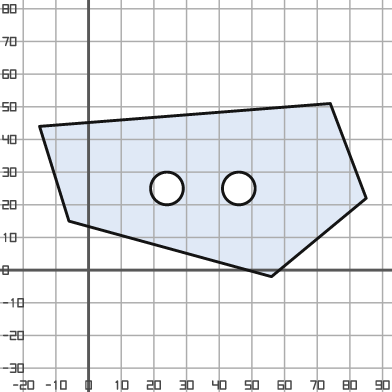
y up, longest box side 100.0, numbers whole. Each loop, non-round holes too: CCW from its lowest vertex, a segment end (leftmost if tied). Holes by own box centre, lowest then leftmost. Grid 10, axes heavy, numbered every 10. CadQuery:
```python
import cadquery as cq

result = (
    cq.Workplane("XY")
    .moveTo(56.0, -2.0)
    .lineTo(85.0, 22.0)
    .lineTo(74.0, 51.0)
    .lineTo(-15.0, 44.0)
    .lineTo(-6.0, 15.0)
    .close()
    .moveTo(24.0, 25.0)
    .circle(5.0)
    .moveTo(46.0, 25.0)
    .circle(5.0)
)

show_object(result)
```